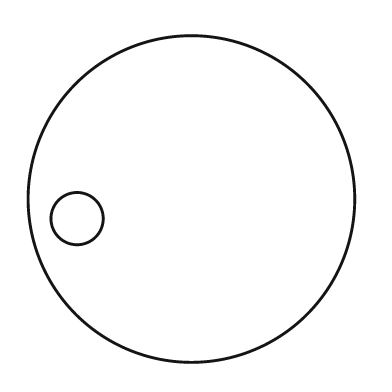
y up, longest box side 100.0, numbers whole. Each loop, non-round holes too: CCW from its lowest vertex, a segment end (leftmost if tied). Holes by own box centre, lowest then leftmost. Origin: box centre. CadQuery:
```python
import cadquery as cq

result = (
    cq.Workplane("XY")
    .moveTo(0.0, 0.0)
    .circle(50.0)
    .moveTo(-35.0, -6.0)
    .circle(8.0)
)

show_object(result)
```